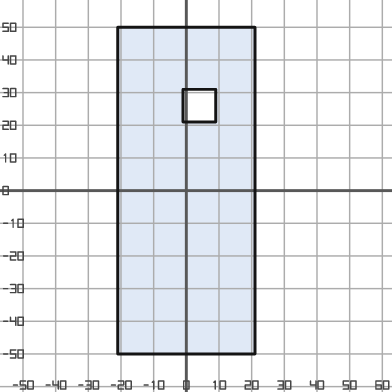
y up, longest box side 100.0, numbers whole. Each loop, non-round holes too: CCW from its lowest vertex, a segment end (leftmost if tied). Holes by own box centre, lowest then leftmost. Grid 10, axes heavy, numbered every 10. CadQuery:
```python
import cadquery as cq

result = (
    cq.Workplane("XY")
    .moveTo(-21.0, -50.0)
    .lineTo(21.0, -50.0)
    .lineTo(21.0, 50.0)
    .lineTo(-21.0, 50.0)
    .close()
    .moveTo(-1.0, 21.0)
    .lineTo(9.0, 21.0)
    .lineTo(9.0, 31.0)
    .lineTo(-1.0, 31.0)
    .close()
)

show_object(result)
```